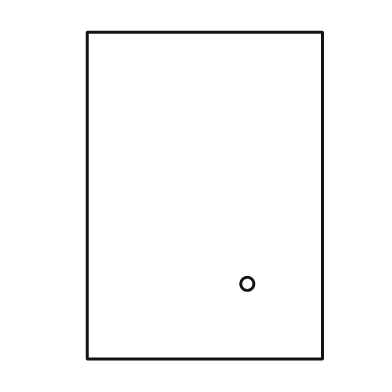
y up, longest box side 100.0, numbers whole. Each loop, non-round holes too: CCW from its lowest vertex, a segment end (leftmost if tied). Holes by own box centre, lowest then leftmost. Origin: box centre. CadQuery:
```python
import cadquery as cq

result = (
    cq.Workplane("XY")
    .moveTo(-36.0, -50.0)
    .lineTo(36.0, -50.0)
    .lineTo(36.0, 50.0)
    .lineTo(-36.0, 50.0)
    .close()
    .moveTo(13.0, -27.0)
    .circle(2.0)
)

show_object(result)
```